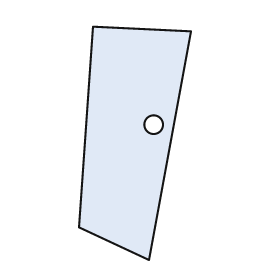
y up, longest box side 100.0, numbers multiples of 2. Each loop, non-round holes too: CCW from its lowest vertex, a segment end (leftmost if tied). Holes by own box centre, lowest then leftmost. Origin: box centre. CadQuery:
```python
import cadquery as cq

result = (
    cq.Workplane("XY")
    .moveTo(6.0, -50.0)
    .lineTo(24.0, 48.0)
    .lineTo(-18.0, 50.0)
    .lineTo(-24.0, -36.0)
    .close()
    .moveTo(8.0, 8.0)
    .circle(4.0)
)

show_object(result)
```